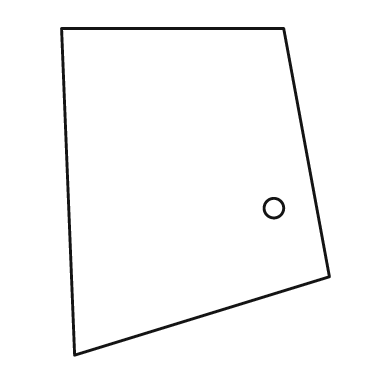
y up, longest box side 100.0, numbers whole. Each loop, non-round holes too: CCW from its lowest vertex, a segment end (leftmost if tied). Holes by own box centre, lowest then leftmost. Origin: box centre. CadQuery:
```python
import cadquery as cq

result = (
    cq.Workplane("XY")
    .moveTo(-37.0, -50.0)
    .lineTo(41.0, -26.0)
    .lineTo(27.0, 50.0)
    .lineTo(-41.0, 50.0)
    .close()
    .moveTo(24.0, -5.0)
    .circle(3.0)
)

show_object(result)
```